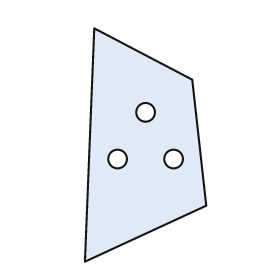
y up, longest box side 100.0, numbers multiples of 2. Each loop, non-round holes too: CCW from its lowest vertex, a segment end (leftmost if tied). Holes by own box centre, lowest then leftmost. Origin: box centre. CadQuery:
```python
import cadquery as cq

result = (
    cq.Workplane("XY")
    .moveTo(-26.0, -50.0)
    .lineTo(26.0, -26.0)
    .lineTo(20.0, 28.0)
    .lineTo(-22.0, 50.0)
    .close()
    .moveTo(-12.0, -6.0)
    .circle(4.0)
    .moveTo(12.0, -6.0)
    .circle(4.0)
    .moveTo(0.0, 14.0)
    .circle(4.0)
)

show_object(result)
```